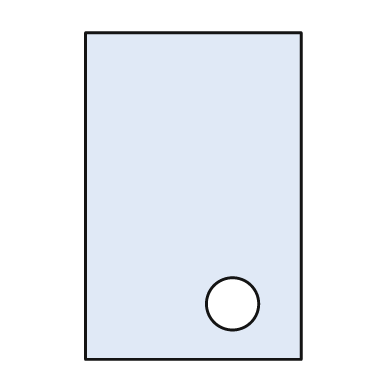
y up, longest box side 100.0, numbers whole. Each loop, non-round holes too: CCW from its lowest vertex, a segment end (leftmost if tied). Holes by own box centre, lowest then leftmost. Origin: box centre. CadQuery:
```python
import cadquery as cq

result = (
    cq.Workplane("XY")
    .moveTo(-33.0, -50.0)
    .lineTo(33.0, -50.0)
    .lineTo(33.0, 50.0)
    .lineTo(-33.0, 50.0)
    .close()
    .moveTo(12.0, -33.0)
    .circle(8.0)
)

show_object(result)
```